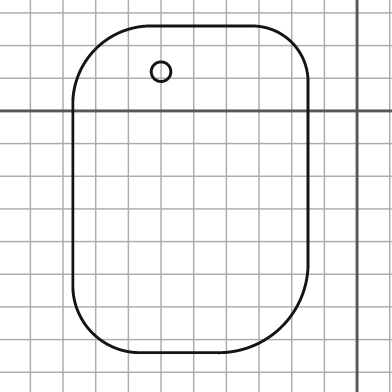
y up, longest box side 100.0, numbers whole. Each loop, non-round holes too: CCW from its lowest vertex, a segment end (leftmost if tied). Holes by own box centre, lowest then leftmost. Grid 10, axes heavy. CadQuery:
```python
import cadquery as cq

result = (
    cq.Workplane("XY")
    .moveTo(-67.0, -74.0)
    .lineTo(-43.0, -74.0)
    .threePointArc((-23.0, -66.0), (-15.0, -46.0))
    .lineTo(-15.0, 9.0)
    .threePointArc((-20.0, 21.0), (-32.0, 26.0))
    .lineTo(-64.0, 26.0)
    .threePointArc((-80.0, 19.0), (-87.0, 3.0))
    .lineTo(-87.0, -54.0)
    .threePointArc((-81.0, -68.0), (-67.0, -74.0))
    .close()
    .moveTo(-60.0, 12.0)
    .circle(3.0)
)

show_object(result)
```